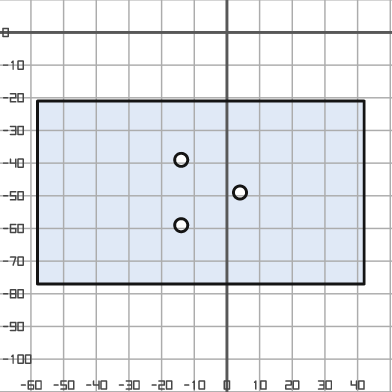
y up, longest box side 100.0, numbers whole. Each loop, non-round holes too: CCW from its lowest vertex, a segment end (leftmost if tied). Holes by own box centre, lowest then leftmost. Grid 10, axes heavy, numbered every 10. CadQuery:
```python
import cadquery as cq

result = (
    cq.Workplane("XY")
    .moveTo(-58.0, -77.0)
    .lineTo(42.0, -77.0)
    .lineTo(42.0, -21.0)
    .lineTo(-58.0, -21.0)
    .close()
    .moveTo(-14.0, -59.0)
    .circle(2.0)
    .moveTo(4.0, -49.0)
    .circle(2.0)
    .moveTo(-14.0, -39.0)
    .circle(2.0)
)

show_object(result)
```